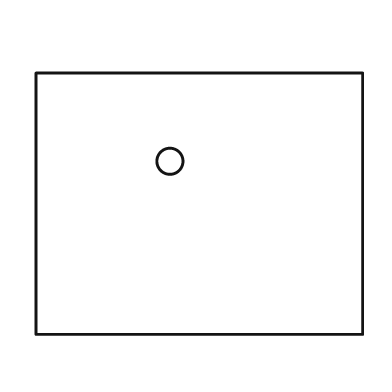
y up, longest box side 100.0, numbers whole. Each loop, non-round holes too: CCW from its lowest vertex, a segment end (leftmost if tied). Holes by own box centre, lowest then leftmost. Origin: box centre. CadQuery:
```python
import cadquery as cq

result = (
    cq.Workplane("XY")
    .moveTo(-50.0, -40.0)
    .lineTo(50.0, -40.0)
    .lineTo(50.0, 40.0)
    .lineTo(-50.0, 40.0)
    .close()
    .moveTo(-9.0, 13.0)
    .circle(4.0)
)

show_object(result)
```